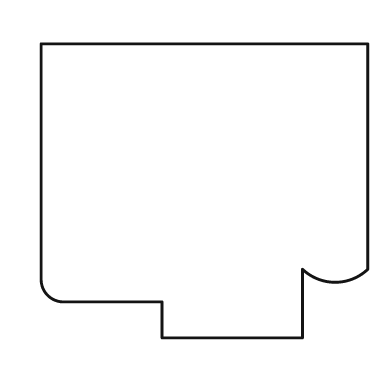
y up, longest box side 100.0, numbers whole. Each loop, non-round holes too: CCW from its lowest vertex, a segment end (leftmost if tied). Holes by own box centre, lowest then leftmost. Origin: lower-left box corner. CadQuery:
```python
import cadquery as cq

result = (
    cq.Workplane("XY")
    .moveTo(37.0, 0.0)
    .lineTo(80.0, 0.0)
    .lineTo(80.0, 21.0)
    .threePointArc((90.0, 17.0), (100.0, 21.0))
    .lineTo(100.0, 90.0)
    .lineTo(0.0, 90.0)
    .lineTo(0.0, 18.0)
    .threePointArc((2.0, 13.0), (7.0, 11.0))
    .lineTo(37.0, 11.0)
    .close()
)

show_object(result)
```